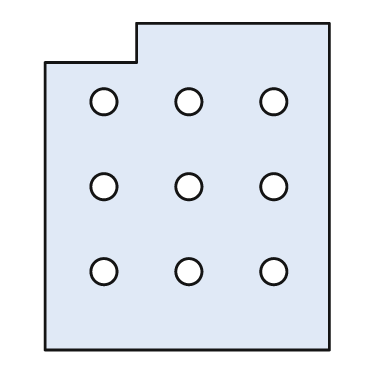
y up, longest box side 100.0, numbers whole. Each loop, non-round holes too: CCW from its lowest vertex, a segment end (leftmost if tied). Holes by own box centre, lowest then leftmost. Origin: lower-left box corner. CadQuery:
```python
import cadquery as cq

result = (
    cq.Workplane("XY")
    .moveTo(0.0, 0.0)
    .lineTo(87.0, 0.0)
    .lineTo(87.0, 100.0)
    .lineTo(28.0, 100.0)
    .lineTo(28.0, 88.0)
    .lineTo(0.0, 88.0)
    .close()
    .moveTo(18.0, 24.0)
    .circle(4.0)
    .moveTo(44.0, 24.0)
    .circle(4.0)
    .moveTo(70.0, 24.0)
    .circle(4.0)
    .moveTo(18.0, 50.0)
    .circle(4.0)
    .moveTo(44.0, 50.0)
    .circle(4.0)
    .moveTo(70.0, 50.0)
    .circle(4.0)
    .moveTo(18.0, 76.0)
    .circle(4.0)
    .moveTo(44.0, 76.0)
    .circle(4.0)
    .moveTo(70.0, 76.0)
    .circle(4.0)
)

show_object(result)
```